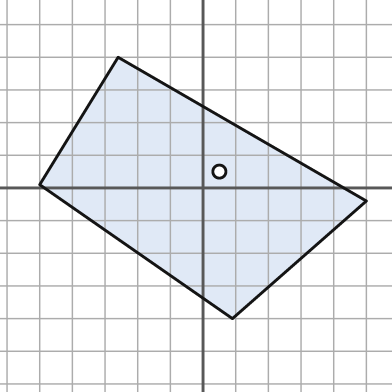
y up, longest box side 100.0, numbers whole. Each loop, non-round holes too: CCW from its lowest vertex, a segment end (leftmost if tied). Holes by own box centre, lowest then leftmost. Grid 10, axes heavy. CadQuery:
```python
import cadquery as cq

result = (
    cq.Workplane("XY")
    .moveTo(9.0, -40.0)
    .lineTo(50.0, -4.0)
    .lineTo(-26.0, 40.0)
    .lineTo(-50.0, 1.0)
    .close()
    .moveTo(5.0, 5.0)
    .circle(2.0)
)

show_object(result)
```